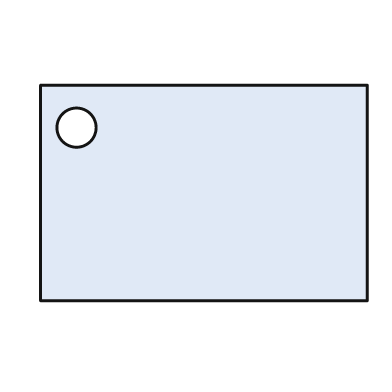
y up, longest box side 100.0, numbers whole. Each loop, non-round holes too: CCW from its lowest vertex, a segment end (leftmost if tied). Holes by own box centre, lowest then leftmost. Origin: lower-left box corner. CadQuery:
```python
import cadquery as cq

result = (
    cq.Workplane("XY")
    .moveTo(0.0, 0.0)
    .lineTo(100.0, 0.0)
    .lineTo(100.0, 66.0)
    .lineTo(0.0, 66.0)
    .close()
    .moveTo(11.0, 53.0)
    .circle(6.0)
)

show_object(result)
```